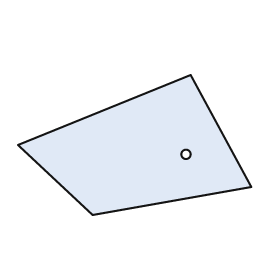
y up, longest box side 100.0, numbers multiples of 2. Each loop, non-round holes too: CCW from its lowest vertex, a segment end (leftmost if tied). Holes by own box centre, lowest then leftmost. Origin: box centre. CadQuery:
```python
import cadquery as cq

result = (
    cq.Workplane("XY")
    .moveTo(-18.0, -30.0)
    .lineTo(50.0, -18.0)
    .lineTo(24.0, 30.0)
    .lineTo(-50.0, 0.0)
    .close()
    .moveTo(22.0, -4.0)
    .circle(2.0)
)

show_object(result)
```